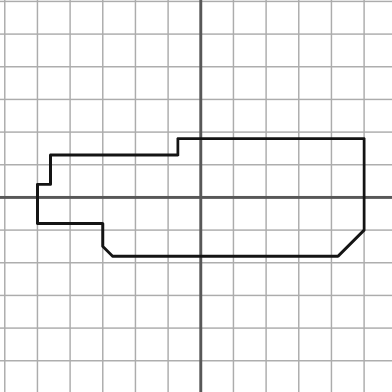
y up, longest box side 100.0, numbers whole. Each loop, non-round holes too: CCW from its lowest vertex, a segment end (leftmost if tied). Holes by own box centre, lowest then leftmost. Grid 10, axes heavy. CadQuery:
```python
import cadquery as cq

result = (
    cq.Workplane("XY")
    .moveTo(-27.0, -18.0)
    .lineTo(42.0, -18.0)
    .lineTo(50.0, -10.0)
    .lineTo(50.0, 18.0)
    .lineTo(-7.0, 18.0)
    .lineTo(-7.0, 13.0)
    .lineTo(-46.0, 13.0)
    .lineTo(-46.0, 4.0)
    .lineTo(-50.0, 4.0)
    .lineTo(-50.0, -8.0)
    .lineTo(-30.0, -8.0)
    .lineTo(-30.0, -15.0)
    .close()
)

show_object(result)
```